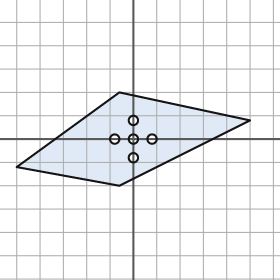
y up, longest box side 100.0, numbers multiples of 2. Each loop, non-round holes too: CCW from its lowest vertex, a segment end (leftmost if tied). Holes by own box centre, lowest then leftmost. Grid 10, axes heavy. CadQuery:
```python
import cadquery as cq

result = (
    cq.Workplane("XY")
    .moveTo(-6.0, -20.0)
    .lineTo(50.0, 8.0)
    .lineTo(-6.0, 20.0)
    .lineTo(-50.0, -12.0)
    .close()
    .moveTo(0.0, -8.0)
    .circle(2.0)
    .moveTo(-8.0, 0.0)
    .circle(2.0)
    .moveTo(0.0, 0.0)
    .circle(2.0)
    .moveTo(8.0, 0.0)
    .circle(2.0)
    .moveTo(0.0, 8.0)
    .circle(2.0)
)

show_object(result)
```